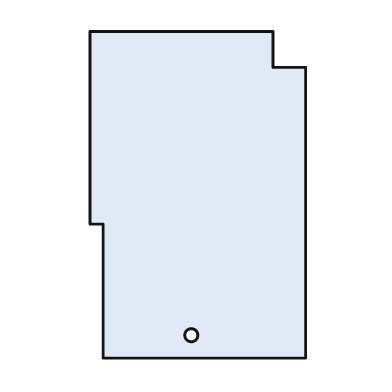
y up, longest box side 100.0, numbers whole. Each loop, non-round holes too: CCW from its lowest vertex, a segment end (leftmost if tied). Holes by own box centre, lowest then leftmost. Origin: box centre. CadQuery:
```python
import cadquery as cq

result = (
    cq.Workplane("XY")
    .moveTo(-29.0, -50.0)
    .lineTo(33.0, -50.0)
    .lineTo(33.0, 39.0)
    .lineTo(23.0, 39.0)
    .lineTo(23.0, 50.0)
    .lineTo(-33.0, 50.0)
    .lineTo(-33.0, -9.0)
    .lineTo(-29.0, -9.0)
    .close()
    .moveTo(-2.0, -43.0)
    .circle(2.0)
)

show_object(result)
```